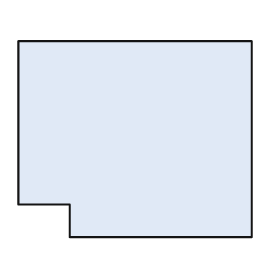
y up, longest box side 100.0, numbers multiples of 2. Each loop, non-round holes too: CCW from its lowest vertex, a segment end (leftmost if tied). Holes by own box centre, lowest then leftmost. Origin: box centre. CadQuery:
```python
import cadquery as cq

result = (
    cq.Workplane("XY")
    .moveTo(-28.0, -42.0)
    .lineTo(50.0, -42.0)
    .lineTo(50.0, 42.0)
    .lineTo(-50.0, 42.0)
    .lineTo(-50.0, -28.0)
    .lineTo(-28.0, -28.0)
    .close()
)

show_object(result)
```